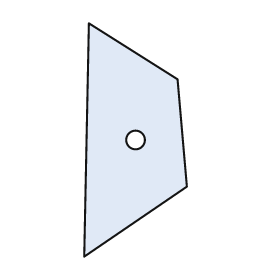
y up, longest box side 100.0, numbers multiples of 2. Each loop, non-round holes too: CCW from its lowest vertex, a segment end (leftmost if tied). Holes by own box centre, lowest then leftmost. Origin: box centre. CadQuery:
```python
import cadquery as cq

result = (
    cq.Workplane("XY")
    .moveTo(-22.0, -50.0)
    .lineTo(22.0, -20.0)
    .lineTo(18.0, 26.0)
    .lineTo(-20.0, 50.0)
    .close()
    .moveTo(0.0, 0.0)
    .circle(4.0)
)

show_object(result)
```